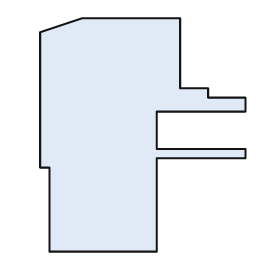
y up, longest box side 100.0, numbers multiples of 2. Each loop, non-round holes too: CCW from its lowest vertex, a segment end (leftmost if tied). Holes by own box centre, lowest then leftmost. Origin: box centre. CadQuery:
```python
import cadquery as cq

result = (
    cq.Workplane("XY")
    .moveTo(-40.0, -50.0)
    .lineTo(6.0, -50.0)
    .lineTo(6.0, -10.0)
    .lineTo(44.0, -10.0)
    .lineTo(44.0, -6.0)
    .lineTo(6.0, -6.0)
    .lineTo(6.0, 10.0)
    .lineTo(44.0, 10.0)
    .lineTo(44.0, 16.0)
    .lineTo(28.0, 16.0)
    .lineTo(28.0, 20.0)
    .lineTo(16.0, 20.0)
    .lineTo(16.0, 50.0)
    .lineTo(-26.0, 50.0)
    .lineTo(-44.0, 44.0)
    .lineTo(-44.0, -14.0)
    .lineTo(-40.0, -14.0)
    .close()
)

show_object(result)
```